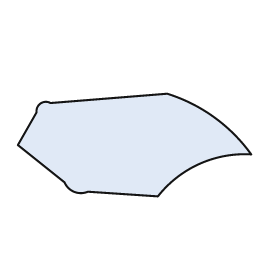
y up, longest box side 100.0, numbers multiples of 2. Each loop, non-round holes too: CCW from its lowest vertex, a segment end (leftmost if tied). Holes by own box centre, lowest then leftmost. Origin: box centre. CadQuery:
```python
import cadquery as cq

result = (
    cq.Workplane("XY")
    .moveTo(10.0, -22.0)
    .threePointArc((28.0, -8.0), (50.0, -4.0))
    .threePointArc((34.0, 12.0), (14.0, 22.0))
    .lineTo(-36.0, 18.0)
    .threePointArc((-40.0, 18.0), (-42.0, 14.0))
    .lineTo(-50.0, 0.0)
    .lineTo(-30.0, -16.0)
    .threePointArc((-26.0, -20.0), (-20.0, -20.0))
    .close()
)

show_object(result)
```